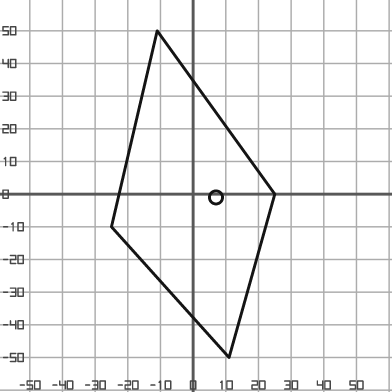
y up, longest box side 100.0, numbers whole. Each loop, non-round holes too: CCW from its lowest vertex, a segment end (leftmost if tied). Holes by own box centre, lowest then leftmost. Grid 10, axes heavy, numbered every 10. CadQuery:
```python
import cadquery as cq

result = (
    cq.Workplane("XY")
    .moveTo(11.0, -50.0)
    .lineTo(25.0, 0.0)
    .lineTo(-11.0, 50.0)
    .lineTo(-25.0, -10.0)
    .close()
    .moveTo(7.0, -1.0)
    .circle(2.0)
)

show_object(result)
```